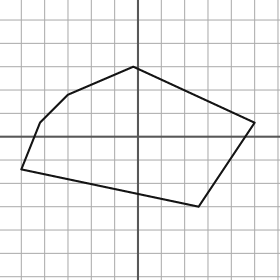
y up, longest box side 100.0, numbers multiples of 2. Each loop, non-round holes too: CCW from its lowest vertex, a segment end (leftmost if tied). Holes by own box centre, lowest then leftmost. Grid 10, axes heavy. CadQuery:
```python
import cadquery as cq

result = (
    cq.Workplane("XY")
    .moveTo(26.0, -30.0)
    .lineTo(50.0, 6.0)
    .lineTo(-2.0, 30.0)
    .lineTo(-30.0, 18.0)
    .lineTo(-42.0, 6.0)
    .lineTo(-50.0, -14.0)
    .close()
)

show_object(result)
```